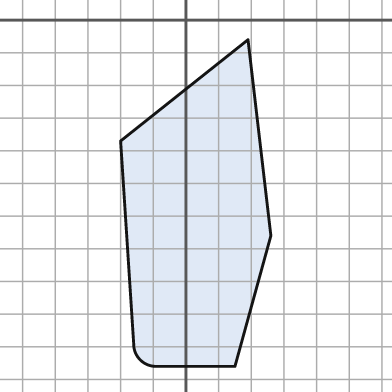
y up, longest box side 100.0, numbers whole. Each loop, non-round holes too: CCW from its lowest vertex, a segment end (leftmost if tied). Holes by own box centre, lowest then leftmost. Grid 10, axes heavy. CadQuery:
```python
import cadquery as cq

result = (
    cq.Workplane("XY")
    .moveTo(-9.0, -106.0)
    .lineTo(15.0, -106.0)
    .lineTo(26.0, -66.0)
    .lineTo(19.0, -6.0)
    .lineTo(-20.0, -37.0)
    .lineTo(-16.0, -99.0)
    .threePointArc((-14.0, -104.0), (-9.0, -106.0))
    .close()
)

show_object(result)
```